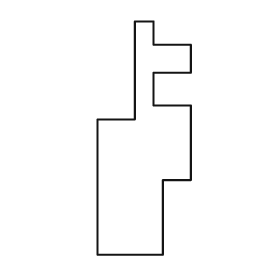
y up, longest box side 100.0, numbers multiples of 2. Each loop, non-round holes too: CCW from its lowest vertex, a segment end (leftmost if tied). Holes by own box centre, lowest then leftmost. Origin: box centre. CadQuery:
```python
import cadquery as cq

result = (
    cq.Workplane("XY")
    .moveTo(-20.0, -50.0)
    .lineTo(8.0, -50.0)
    .lineTo(8.0, -18.0)
    .lineTo(20.0, -18.0)
    .lineTo(20.0, 14.0)
    .lineTo(4.0, 14.0)
    .lineTo(4.0, 28.0)
    .lineTo(20.0, 28.0)
    .lineTo(20.0, 40.0)
    .lineTo(4.0, 40.0)
    .lineTo(4.0, 50.0)
    .lineTo(-4.0, 50.0)
    .lineTo(-4.0, 8.0)
    .lineTo(-20.0, 8.0)
    .close()
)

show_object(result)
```